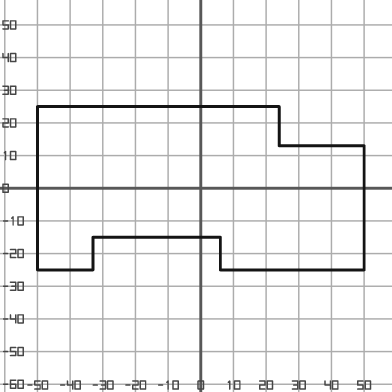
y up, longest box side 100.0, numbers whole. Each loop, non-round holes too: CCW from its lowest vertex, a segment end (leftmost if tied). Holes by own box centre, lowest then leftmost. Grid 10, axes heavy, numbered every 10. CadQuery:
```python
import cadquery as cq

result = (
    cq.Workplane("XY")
    .moveTo(-50.0, -25.0)
    .lineTo(-33.0, -25.0)
    .lineTo(-33.0, -15.0)
    .lineTo(6.0, -15.0)
    .lineTo(6.0, -25.0)
    .lineTo(50.0, -25.0)
    .lineTo(50.0, 13.0)
    .lineTo(24.0, 13.0)
    .lineTo(24.0, 25.0)
    .lineTo(-50.0, 25.0)
    .close()
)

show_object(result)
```